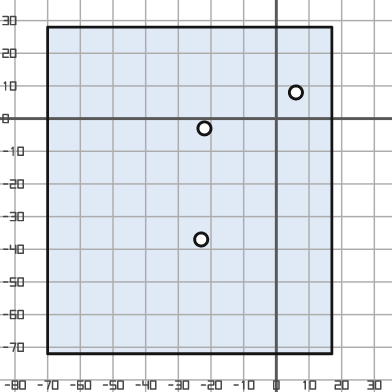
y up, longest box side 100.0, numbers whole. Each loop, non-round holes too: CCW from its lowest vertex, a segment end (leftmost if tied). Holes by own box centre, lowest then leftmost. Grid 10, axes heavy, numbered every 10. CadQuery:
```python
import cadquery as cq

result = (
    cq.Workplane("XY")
    .moveTo(-70.0, -72.0)
    .lineTo(17.0, -72.0)
    .lineTo(17.0, 28.0)
    .lineTo(-70.0, 28.0)
    .close()
    .moveTo(-23.0, -37.0)
    .circle(2.0)
    .moveTo(-22.0, -3.0)
    .circle(2.0)
    .moveTo(6.0, 8.0)
    .circle(2.0)
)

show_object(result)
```